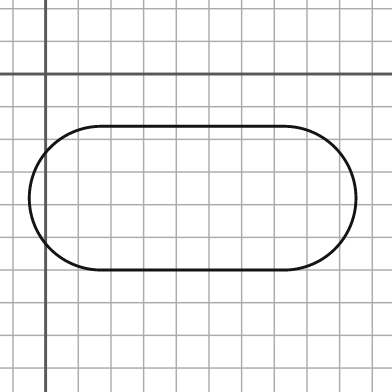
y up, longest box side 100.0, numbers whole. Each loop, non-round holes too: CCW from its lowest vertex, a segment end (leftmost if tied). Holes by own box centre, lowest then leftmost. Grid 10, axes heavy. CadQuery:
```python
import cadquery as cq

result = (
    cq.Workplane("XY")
    .moveTo(17.0, -60.0)
    .lineTo(73.0, -60.0)
    .threePointArc((95.0, -38.0), (73.0, -16.0))
    .lineTo(17.0, -16.0)
    .threePointArc((-5.0, -38.0), (17.0, -60.0))
    .close()
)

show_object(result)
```